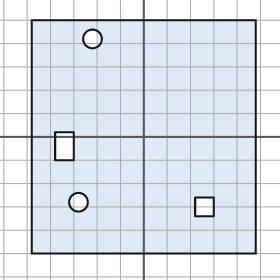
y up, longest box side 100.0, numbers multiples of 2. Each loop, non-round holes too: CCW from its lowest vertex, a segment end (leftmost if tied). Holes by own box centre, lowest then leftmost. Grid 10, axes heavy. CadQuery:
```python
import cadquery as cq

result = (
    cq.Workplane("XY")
    .moveTo(-48.0, -50.0)
    .lineTo(48.0, -50.0)
    .lineTo(48.0, 50.0)
    .lineTo(-48.0, 50.0)
    .close()
    .moveTo(22.0, -34.0)
    .lineTo(30.0, -34.0)
    .lineTo(30.0, -26.0)
    .lineTo(22.0, -26.0)
    .close()
    .moveTo(-28.0, -28.0)
    .circle(4.0)
    .moveTo(-38.0, -10.0)
    .lineTo(-30.0, -10.0)
    .lineTo(-30.0, 2.0)
    .lineTo(-38.0, 2.0)
    .close()
    .moveTo(-22.0, 42.0)
    .circle(4.0)
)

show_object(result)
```